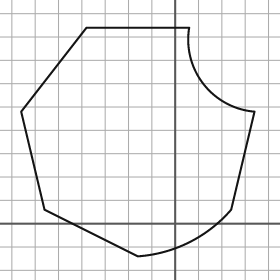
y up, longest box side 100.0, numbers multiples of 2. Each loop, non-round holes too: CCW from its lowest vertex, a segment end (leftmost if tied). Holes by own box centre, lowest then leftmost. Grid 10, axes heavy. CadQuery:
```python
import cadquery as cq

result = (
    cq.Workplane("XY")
    .moveTo(-16.0, -14.0)
    .threePointArc((6.0, -8.0), (24.0, 6.0))
    .lineTo(34.0, 48.0)
    .threePointArc((12.0, 60.0), (6.0, 84.0))
    .lineTo(-38.0, 84.0)
    .lineTo(-66.0, 48.0)
    .lineTo(-56.0, 6.0)
    .close()
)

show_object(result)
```